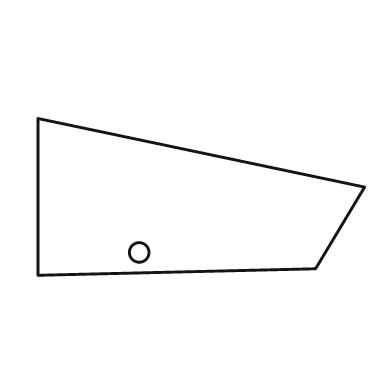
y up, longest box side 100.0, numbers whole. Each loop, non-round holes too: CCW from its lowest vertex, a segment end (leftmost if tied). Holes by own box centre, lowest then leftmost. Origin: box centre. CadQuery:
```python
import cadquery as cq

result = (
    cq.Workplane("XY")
    .moveTo(-50.0, -24.0)
    .lineTo(35.0, -22.0)
    .lineTo(50.0, 3.0)
    .lineTo(-50.0, 24.0)
    .close()
    .moveTo(-19.0, -17.0)
    .circle(3.0)
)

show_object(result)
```